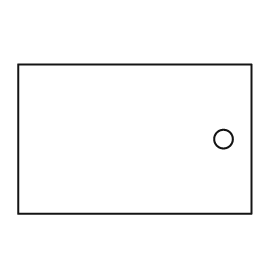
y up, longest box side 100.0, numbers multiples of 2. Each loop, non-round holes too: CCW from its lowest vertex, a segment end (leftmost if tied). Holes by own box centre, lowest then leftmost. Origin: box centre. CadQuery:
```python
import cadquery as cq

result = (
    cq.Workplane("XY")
    .moveTo(-50.0, -32.0)
    .lineTo(50.0, -32.0)
    .lineTo(50.0, 32.0)
    .lineTo(-50.0, 32.0)
    .close()
    .moveTo(38.0, 0.0)
    .circle(4.0)
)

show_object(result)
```